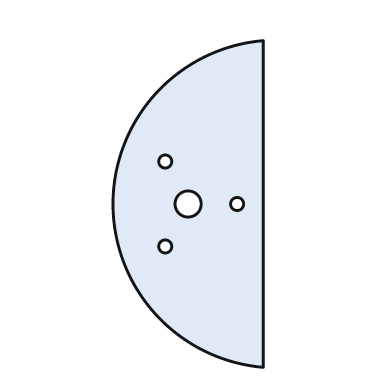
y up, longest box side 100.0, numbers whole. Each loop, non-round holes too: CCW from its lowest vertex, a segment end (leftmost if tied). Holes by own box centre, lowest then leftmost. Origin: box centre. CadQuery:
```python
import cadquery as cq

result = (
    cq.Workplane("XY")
    .moveTo(23.0, -50.0)
    .lineTo(23.0, 50.0)
    .threePointArc((-23.0, 0.0), (23.0, -50.0))
    .close()
    .moveTo(-7.0, -13.0)
    .circle(2.0)
    .moveTo(0.0, 0.0)
    .circle(4.0)
    .moveTo(15.0, 0.0)
    .circle(2.0)
    .moveTo(-7.0, 13.0)
    .circle(2.0)
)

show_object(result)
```